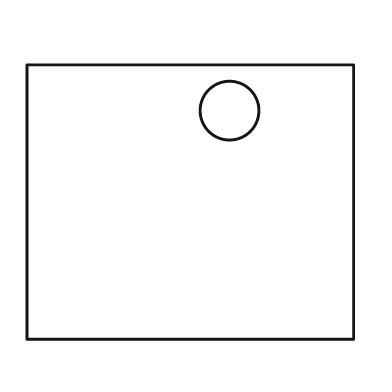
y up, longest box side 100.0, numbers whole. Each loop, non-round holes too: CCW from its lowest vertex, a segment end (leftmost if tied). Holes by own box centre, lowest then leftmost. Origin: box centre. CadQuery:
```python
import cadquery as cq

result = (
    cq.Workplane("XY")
    .moveTo(-50.0, -42.0)
    .lineTo(50.0, -42.0)
    .lineTo(50.0, 42.0)
    .lineTo(-50.0, 42.0)
    .close()
    .moveTo(12.0, 28.0)
    .circle(9.0)
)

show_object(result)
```